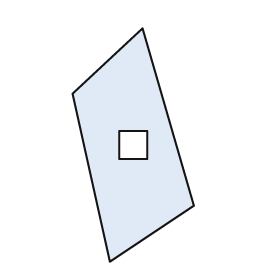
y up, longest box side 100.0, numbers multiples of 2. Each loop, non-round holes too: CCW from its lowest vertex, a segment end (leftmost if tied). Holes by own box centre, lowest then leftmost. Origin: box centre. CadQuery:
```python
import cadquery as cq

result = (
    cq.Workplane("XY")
    .moveTo(-10.0, -50.0)
    .lineTo(26.0, -26.0)
    .lineTo(4.0, 50.0)
    .lineTo(-26.0, 22.0)
    .close()
    .moveTo(-6.0, -6.0)
    .lineTo(6.0, -6.0)
    .lineTo(6.0, 6.0)
    .lineTo(-6.0, 6.0)
    .close()
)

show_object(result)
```